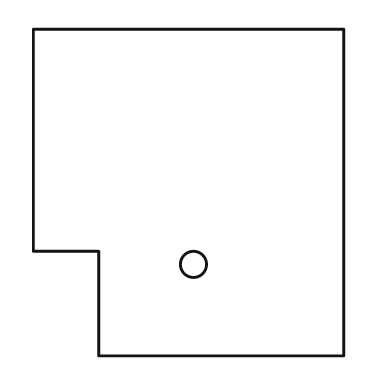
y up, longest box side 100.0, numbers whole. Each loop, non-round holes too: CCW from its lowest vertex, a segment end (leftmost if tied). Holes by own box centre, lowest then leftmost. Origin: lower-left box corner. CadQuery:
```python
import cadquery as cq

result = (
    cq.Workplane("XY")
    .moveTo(20.0, 0.0)
    .lineTo(95.0, 0.0)
    .lineTo(95.0, 100.0)
    .lineTo(0.0, 100.0)
    .lineTo(0.0, 32.0)
    .lineTo(20.0, 32.0)
    .close()
    .moveTo(49.0, 28.0)
    .circle(4.0)
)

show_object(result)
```